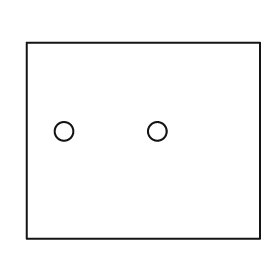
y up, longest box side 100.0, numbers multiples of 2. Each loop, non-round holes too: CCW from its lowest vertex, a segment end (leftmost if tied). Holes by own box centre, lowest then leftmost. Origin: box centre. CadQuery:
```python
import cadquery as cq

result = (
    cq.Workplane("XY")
    .moveTo(-50.0, -42.0)
    .lineTo(50.0, -42.0)
    .lineTo(50.0, 42.0)
    .lineTo(-50.0, 42.0)
    .close()
    .moveTo(-34.0, 4.0)
    .circle(4.0)
    .moveTo(6.0, 4.0)
    .circle(4.0)
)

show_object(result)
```